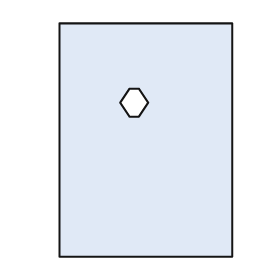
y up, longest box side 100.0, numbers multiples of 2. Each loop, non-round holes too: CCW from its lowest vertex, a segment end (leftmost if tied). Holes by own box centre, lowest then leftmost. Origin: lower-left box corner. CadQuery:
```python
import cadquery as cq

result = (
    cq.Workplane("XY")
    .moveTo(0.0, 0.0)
    .lineTo(74.0, 0.0)
    .lineTo(74.0, 100.0)
    .lineTo(0.0, 100.0)
    .close()
    .moveTo(30.0, 60.0)
    .lineTo(34.0, 60.0)
    .lineTo(38.0, 66.0)
    .lineTo(34.0, 72.0)
    .lineTo(30.0, 72.0)
    .lineTo(26.0, 66.0)
    .close()
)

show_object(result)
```